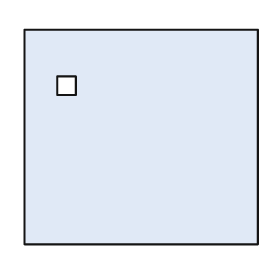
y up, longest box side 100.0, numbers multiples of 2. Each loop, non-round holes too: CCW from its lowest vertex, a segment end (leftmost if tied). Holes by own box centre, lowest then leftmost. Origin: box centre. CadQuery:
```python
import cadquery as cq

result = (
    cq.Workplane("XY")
    .moveTo(-50.0, -46.0)
    .lineTo(50.0, -46.0)
    .lineTo(50.0, 46.0)
    .lineTo(-50.0, 46.0)
    .close()
    .moveTo(-36.0, 18.0)
    .lineTo(-28.0, 18.0)
    .lineTo(-28.0, 26.0)
    .lineTo(-36.0, 26.0)
    .close()
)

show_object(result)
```